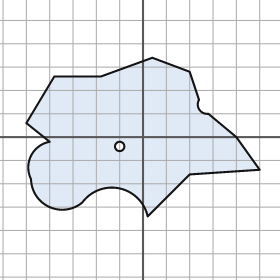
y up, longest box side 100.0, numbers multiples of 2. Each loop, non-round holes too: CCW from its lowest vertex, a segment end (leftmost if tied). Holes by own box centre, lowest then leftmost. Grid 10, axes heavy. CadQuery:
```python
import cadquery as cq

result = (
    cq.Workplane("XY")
    .moveTo(2.0, -34.0)
    .lineTo(20.0, -16.0)
    .lineTo(50.0, -14.0)
    .lineTo(40.0, 0.0)
    .lineTo(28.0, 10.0)
    .threePointArc((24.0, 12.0), (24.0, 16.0))
    .lineTo(20.0, 28.0)
    .lineTo(4.0, 34.0)
    .lineTo(-18.0, 26.0)
    .lineTo(-38.0, 26.0)
    .lineTo(-50.0, 6.0)
    .lineTo(-40.0, -2.0)
    .threePointArc((-48.0, -8.0), (-48.0, -18.0))
    .threePointArc((-40.0, -30.0), (-26.0, -28.0))
    .threePointArc((-10.0, -22.0), (2.0, -34.0))
    .close()
    .moveTo(-10.0, -4.0)
    .circle(2.0)
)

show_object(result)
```